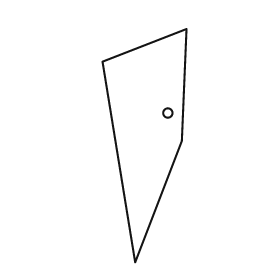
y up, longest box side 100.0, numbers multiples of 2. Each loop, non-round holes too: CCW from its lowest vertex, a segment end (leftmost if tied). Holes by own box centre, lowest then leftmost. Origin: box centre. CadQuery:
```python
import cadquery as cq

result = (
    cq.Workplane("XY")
    .moveTo(-4.0, -50.0)
    .lineTo(16.0, 2.0)
    .lineTo(18.0, 50.0)
    .lineTo(-18.0, 36.0)
    .close()
    .moveTo(10.0, 14.0)
    .circle(2.0)
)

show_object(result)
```